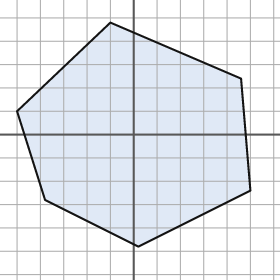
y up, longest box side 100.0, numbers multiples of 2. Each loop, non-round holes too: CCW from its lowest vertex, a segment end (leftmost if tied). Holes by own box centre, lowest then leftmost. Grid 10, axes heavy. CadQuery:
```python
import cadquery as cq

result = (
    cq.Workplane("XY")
    .moveTo(2.0, -48.0)
    .lineTo(50.0, -24.0)
    .lineTo(46.0, 24.0)
    .lineTo(-10.0, 48.0)
    .lineTo(-50.0, 10.0)
    .lineTo(-38.0, -28.0)
    .close()
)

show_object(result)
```